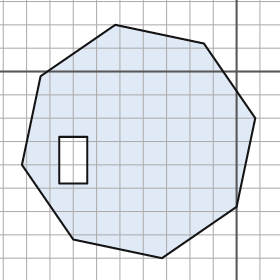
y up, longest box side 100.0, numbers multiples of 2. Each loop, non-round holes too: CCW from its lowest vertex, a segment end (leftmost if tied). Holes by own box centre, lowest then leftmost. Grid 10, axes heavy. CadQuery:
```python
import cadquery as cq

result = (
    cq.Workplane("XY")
    .moveTo(-32.0, -80.0)
    .lineTo(0.0, -58.0)
    .lineTo(8.0, -20.0)
    .lineTo(-14.0, 12.0)
    .lineTo(-52.0, 20.0)
    .lineTo(-84.0, -2.0)
    .lineTo(-92.0, -40.0)
    .lineTo(-70.0, -72.0)
    .close()
    .moveTo(-76.0, -48.0)
    .lineTo(-64.0, -48.0)
    .lineTo(-64.0, -28.0)
    .lineTo(-76.0, -28.0)
    .close()
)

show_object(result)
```